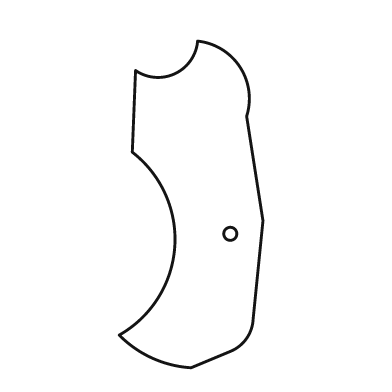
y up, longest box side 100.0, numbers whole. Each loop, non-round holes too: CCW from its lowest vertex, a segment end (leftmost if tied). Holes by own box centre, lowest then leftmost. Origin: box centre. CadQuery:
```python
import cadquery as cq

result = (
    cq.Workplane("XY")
    .moveTo(0.0, -50.0)
    .lineTo(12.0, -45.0)
    .threePointArc((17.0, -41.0), (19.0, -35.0))
    .lineTo(22.0, -5.0)
    .lineTo(17.0, 27.0)
    .threePointArc((15.0, 42.0), (2.0, 50.0))
    .threePointArc((-5.0, 40.0), (-17.0, 41.0))
    .lineTo(-18.0, 16.0)
    .threePointArc((-5.0, -13.0), (-22.0, -40.0))
    .threePointArc((-12.0, -47.0), (0.0, -50.0))
    .close()
    .moveTo(12.0, -9.0)
    .circle(2.0)
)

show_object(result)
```